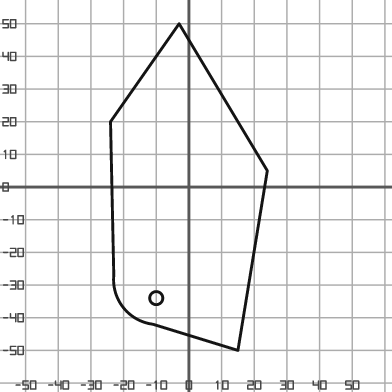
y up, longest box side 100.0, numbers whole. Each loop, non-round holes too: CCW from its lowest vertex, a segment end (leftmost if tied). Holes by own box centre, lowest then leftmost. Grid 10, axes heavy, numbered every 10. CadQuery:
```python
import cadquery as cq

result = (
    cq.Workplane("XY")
    .moveTo(15.0, -50.0)
    .lineTo(24.0, 5.0)
    .lineTo(-3.0, 50.0)
    .lineTo(-24.0, 20.0)
    .lineTo(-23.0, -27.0)
    .threePointArc((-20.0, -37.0), (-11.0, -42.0))
    .close()
    .moveTo(-10.0, -34.0)
    .circle(2.0)
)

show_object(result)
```